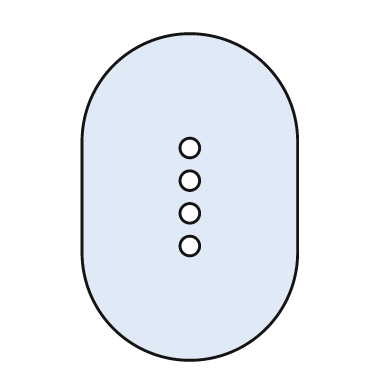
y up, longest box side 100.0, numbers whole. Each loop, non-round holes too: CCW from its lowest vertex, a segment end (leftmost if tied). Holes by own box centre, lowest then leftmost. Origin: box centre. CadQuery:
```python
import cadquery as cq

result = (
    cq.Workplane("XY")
    .moveTo(-33.0, -17.0)
    .threePointArc((0.0, -50.0), (33.0, -17.0))
    .lineTo(33.0, 17.0)
    .threePointArc((0.0, 50.0), (-33.0, 17.0))
    .close()
    .moveTo(0.0, -15.0)
    .circle(3.0)
    .moveTo(0.0, -5.0)
    .circle(3.0)
    .moveTo(0.0, 5.0)
    .circle(3.0)
    .moveTo(0.0, 15.0)
    .circle(3.0)
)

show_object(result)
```